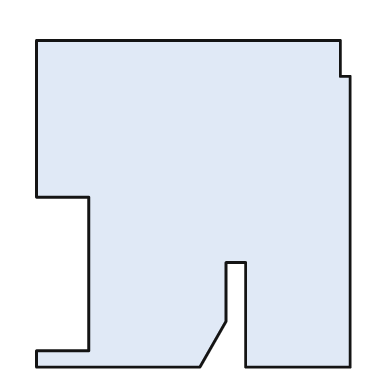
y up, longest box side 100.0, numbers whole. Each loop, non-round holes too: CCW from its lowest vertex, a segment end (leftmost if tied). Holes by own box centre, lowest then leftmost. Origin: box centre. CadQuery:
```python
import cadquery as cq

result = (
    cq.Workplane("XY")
    .moveTo(-48.0, -50.0)
    .lineTo(2.0, -50.0)
    .lineTo(10.0, -36.0)
    .lineTo(10.0, -18.0)
    .lineTo(16.0, -18.0)
    .lineTo(16.0, -50.0)
    .lineTo(48.0, -50.0)
    .lineTo(48.0, 39.0)
    .lineTo(45.0, 39.0)
    .lineTo(45.0, 50.0)
    .lineTo(-48.0, 50.0)
    .lineTo(-48.0, 2.0)
    .lineTo(-32.0, 2.0)
    .lineTo(-32.0, -45.0)
    .lineTo(-48.0, -45.0)
    .close()
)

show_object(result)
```